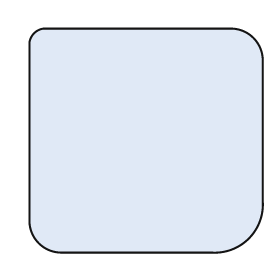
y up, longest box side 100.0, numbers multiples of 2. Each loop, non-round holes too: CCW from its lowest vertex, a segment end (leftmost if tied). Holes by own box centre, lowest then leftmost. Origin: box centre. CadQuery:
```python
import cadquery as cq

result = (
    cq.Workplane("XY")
    .moveTo(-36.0, -48.0)
    .lineTo(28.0, -48.0)
    .threePointArc((44.0, -42.0), (50.0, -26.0))
    .lineTo(50.0, 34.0)
    .threePointArc((46.0, 44.0), (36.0, 48.0))
    .lineTo(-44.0, 48.0)
    .threePointArc((-48.0, 46.0), (-50.0, 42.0))
    .lineTo(-50.0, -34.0)
    .threePointArc((-46.0, -44.0), (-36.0, -48.0))
    .close()
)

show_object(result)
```